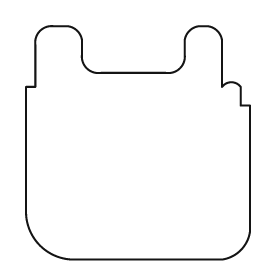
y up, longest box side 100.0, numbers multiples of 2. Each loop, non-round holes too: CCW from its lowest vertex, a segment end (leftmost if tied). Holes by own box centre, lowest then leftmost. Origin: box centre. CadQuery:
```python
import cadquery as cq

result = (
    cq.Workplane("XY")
    .moveTo(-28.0, -50.0)
    .lineTo(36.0, -50.0)
    .threePointArc((44.0, -46.0), (48.0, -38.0))
    .lineTo(48.0, 16.0)
    .lineTo(44.0, 16.0)
    .lineTo(44.0, 24.0)
    .threePointArc((40.0, 26.0), (36.0, 24.0))
    .lineTo(36.0, 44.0)
    .threePointArc((34.0, 48.0), (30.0, 50.0))
    .lineTo(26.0, 50.0)
    .threePointArc((22.0, 48.0), (20.0, 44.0))
    .lineTo(20.0, 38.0)
    .threePointArc((18.0, 32.0), (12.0, 30.0))
    .lineTo(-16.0, 30.0)
    .threePointArc((-22.0, 32.0), (-24.0, 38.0))
    .lineTo(-24.0, 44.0)
    .threePointArc((-26.0, 48.0), (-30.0, 50.0))
    .lineTo(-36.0, 50.0)
    .threePointArc((-42.0, 48.0), (-44.0, 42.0))
    .lineTo(-44.0, 24.0)
    .lineTo(-48.0, 24.0)
    .lineTo(-48.0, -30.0)
    .threePointArc((-42.0, -44.0), (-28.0, -50.0))
    .close()
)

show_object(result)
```